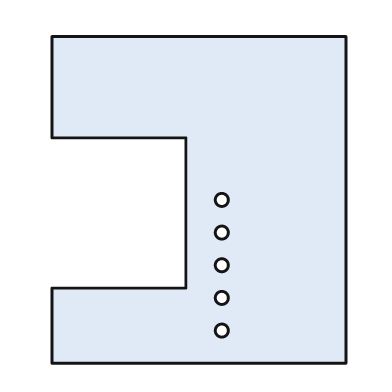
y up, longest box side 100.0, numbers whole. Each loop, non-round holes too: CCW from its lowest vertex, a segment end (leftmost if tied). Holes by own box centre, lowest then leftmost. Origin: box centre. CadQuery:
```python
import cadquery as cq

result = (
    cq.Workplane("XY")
    .moveTo(-45.0, -50.0)
    .lineTo(45.0, -50.0)
    .lineTo(45.0, 50.0)
    .lineTo(-45.0, 50.0)
    .lineTo(-45.0, 19.0)
    .lineTo(-4.0, 19.0)
    .lineTo(-4.0, -27.0)
    .lineTo(-45.0, -27.0)
    .close()
    .moveTo(7.0, -40.0)
    .circle(2.0)
    .moveTo(7.0, -30.0)
    .circle(2.0)
    .moveTo(7.0, -20.0)
    .circle(2.0)
    .moveTo(7.0, -10.0)
    .circle(2.0)
    .moveTo(7.0, 0.0)
    .circle(2.0)
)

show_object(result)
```